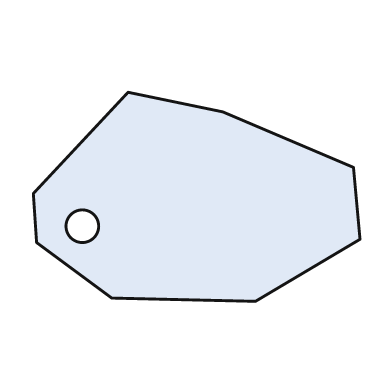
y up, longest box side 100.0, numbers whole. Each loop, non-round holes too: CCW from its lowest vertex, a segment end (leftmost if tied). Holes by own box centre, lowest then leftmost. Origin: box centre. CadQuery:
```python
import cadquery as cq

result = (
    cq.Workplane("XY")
    .moveTo(18.0, -32.0)
    .lineTo(50.0, -13.0)
    .lineTo(48.0, 9.0)
    .lineTo(8.0, 26.0)
    .lineTo(-21.0, 32.0)
    .lineTo(-50.0, 1.0)
    .lineTo(-49.0, -14.0)
    .lineTo(-26.0, -31.0)
    .close()
    .moveTo(-35.0, -9.0)
    .circle(5.0)
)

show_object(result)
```